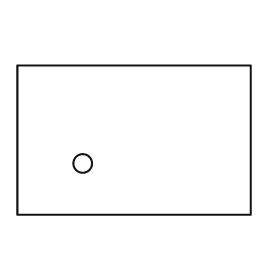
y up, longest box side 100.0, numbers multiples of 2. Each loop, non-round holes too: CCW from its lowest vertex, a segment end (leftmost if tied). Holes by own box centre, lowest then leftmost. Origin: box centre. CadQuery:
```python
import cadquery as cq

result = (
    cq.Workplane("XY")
    .moveTo(-50.0, -32.0)
    .lineTo(50.0, -32.0)
    .lineTo(50.0, 32.0)
    .lineTo(-50.0, 32.0)
    .close()
    .moveTo(-22.0, -10.0)
    .circle(4.0)
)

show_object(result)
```